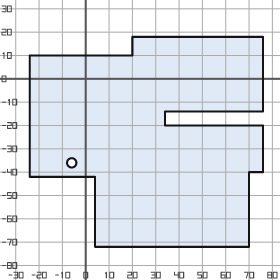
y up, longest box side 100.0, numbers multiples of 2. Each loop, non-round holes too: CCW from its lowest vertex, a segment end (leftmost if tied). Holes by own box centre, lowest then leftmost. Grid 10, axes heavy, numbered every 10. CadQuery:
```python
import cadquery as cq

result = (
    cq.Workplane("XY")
    .moveTo(4.0, -72.0)
    .lineTo(70.0, -72.0)
    .lineTo(70.0, -40.0)
    .lineTo(76.0, -40.0)
    .lineTo(76.0, -20.0)
    .lineTo(34.0, -20.0)
    .lineTo(34.0, -14.0)
    .lineTo(76.0, -14.0)
    .lineTo(76.0, 18.0)
    .lineTo(20.0, 18.0)
    .lineTo(20.0, 10.0)
    .lineTo(-24.0, 10.0)
    .lineTo(-24.0, -42.0)
    .lineTo(4.0, -42.0)
    .close()
    .moveTo(-6.0, -36.0)
    .circle(2.0)
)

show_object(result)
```